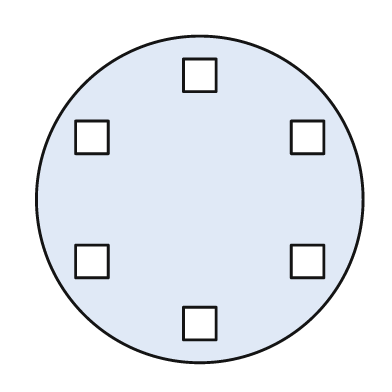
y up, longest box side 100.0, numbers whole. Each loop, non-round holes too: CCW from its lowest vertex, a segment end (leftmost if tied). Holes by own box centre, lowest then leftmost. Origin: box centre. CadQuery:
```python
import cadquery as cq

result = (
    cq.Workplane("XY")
    .moveTo(0.0, 0.0)
    .circle(50.0)
    .moveTo(-5.0, -43.0)
    .lineTo(5.0, -43.0)
    .lineTo(5.0, -33.0)
    .lineTo(-5.0, -33.0)
    .close()
    .moveTo(-38.0, -24.0)
    .lineTo(-28.0, -24.0)
    .lineTo(-28.0, -14.0)
    .lineTo(-38.0, -14.0)
    .close()
    .moveTo(28.0, -24.0)
    .lineTo(38.0, -24.0)
    .lineTo(38.0, -14.0)
    .lineTo(28.0, -14.0)
    .close()
    .moveTo(-38.0, 14.0)
    .lineTo(-28.0, 14.0)
    .lineTo(-28.0, 24.0)
    .lineTo(-38.0, 24.0)
    .close()
    .moveTo(28.0, 14.0)
    .lineTo(38.0, 14.0)
    .lineTo(38.0, 24.0)
    .lineTo(28.0, 24.0)
    .close()
    .moveTo(-5.0, 33.0)
    .lineTo(5.0, 33.0)
    .lineTo(5.0, 43.0)
    .lineTo(-5.0, 43.0)
    .close()
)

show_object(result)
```